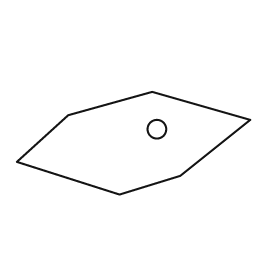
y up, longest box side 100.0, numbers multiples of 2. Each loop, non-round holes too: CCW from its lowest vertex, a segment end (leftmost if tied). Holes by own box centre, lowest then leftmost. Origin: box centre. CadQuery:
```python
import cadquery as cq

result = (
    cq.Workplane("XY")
    .moveTo(-6.0, -22.0)
    .lineTo(20.0, -14.0)
    .lineTo(50.0, 10.0)
    .lineTo(8.0, 22.0)
    .lineTo(-28.0, 12.0)
    .lineTo(-50.0, -8.0)
    .close()
    .moveTo(10.0, 6.0)
    .circle(4.0)
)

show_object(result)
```